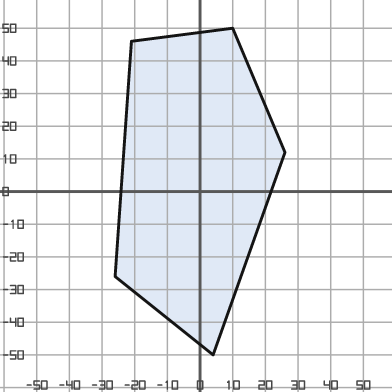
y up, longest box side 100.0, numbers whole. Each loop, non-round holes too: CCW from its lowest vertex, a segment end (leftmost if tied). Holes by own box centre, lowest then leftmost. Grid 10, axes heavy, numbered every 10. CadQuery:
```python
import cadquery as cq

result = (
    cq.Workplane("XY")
    .moveTo(4.0, -50.0)
    .lineTo(26.0, 12.0)
    .lineTo(10.0, 50.0)
    .lineTo(-21.0, 46.0)
    .lineTo(-26.0, -26.0)
    .close()
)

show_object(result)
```